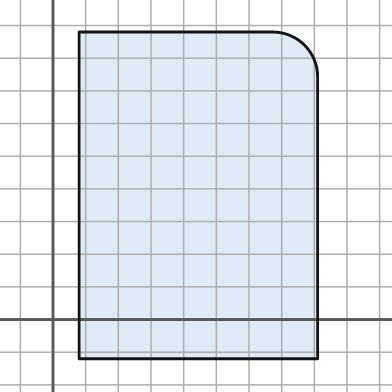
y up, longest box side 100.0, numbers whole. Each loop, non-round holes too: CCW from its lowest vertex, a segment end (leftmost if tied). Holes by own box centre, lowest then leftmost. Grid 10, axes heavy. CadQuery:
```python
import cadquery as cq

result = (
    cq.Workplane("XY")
    .moveTo(8.0, -12.0)
    .lineTo(81.0, -12.0)
    .lineTo(81.0, 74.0)
    .threePointArc((77.0, 84.0), (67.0, 88.0))
    .lineTo(8.0, 88.0)
    .close()
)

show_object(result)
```